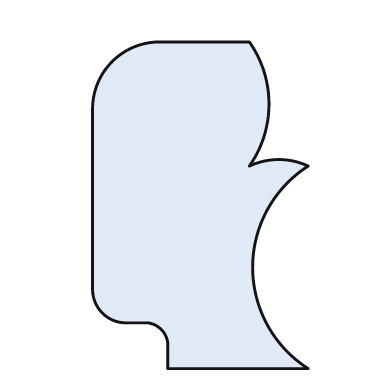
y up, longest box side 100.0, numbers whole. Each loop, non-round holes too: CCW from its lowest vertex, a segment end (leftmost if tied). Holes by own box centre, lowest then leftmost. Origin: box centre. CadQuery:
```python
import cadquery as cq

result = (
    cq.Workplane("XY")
    .moveTo(-10.0, -50.0)
    .lineTo(33.0, -50.0)
    .threePointArc((16.0, -19.0), (33.0, 12.0))
    .threePointArc((24.0, 14.0), (15.0, 12.0))
    .threePointArc((21.0, 31.0), (15.0, 50.0))
    .lineTo(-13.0, 50.0)
    .threePointArc((-27.0, 44.0), (-33.0, 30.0))
    .lineTo(-33.0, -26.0)
    .threePointArc((-30.0, -33.0), (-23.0, -36.0))
    .lineTo(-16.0, -36.0)
    .threePointArc((-12.0, -38.0), (-10.0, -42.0))
    .close()
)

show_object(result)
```